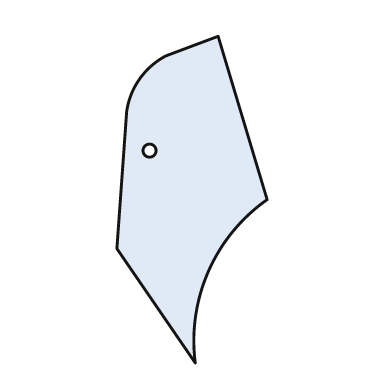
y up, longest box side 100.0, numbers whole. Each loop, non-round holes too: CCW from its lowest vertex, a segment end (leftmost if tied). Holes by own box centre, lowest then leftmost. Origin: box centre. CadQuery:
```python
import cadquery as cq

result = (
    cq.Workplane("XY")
    .moveTo(1.0, -50.0)
    .threePointArc((5.0, -22.0), (23.0, 0.0))
    .lineTo(8.0, 50.0)
    .lineTo(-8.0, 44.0)
    .threePointArc((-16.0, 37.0), (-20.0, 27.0))
    .lineTo(-23.0, -15.0)
    .close()
    .moveTo(-13.0, 15.0)
    .circle(2.0)
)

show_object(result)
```